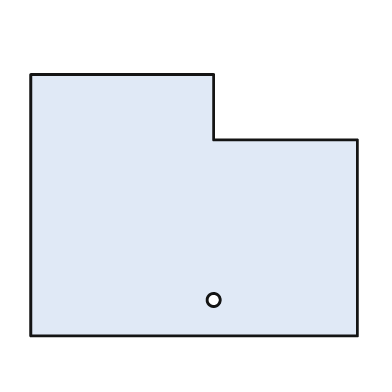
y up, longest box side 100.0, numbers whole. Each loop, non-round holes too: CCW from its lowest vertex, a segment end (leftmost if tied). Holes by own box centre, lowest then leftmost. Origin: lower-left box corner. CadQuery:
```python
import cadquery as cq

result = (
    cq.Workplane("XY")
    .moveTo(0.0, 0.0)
    .lineTo(100.0, 0.0)
    .lineTo(100.0, 60.0)
    .lineTo(56.0, 60.0)
    .lineTo(56.0, 80.0)
    .lineTo(0.0, 80.0)
    .close()
    .moveTo(56.0, 11.0)
    .circle(2.0)
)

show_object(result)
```